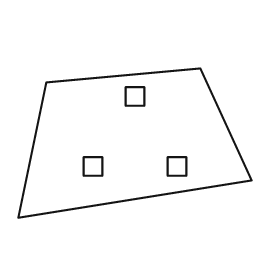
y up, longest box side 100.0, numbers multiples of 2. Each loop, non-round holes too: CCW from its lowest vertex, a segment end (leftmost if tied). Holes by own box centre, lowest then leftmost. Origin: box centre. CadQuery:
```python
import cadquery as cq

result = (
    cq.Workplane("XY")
    .moveTo(-50.0, -32.0)
    .lineTo(50.0, -16.0)
    .lineTo(28.0, 32.0)
    .lineTo(-38.0, 26.0)
    .close()
    .moveTo(-22.0, -14.0)
    .lineTo(-14.0, -14.0)
    .lineTo(-14.0, -6.0)
    .lineTo(-22.0, -6.0)
    .close()
    .moveTo(14.0, -14.0)
    .lineTo(22.0, -14.0)
    .lineTo(22.0, -6.0)
    .lineTo(14.0, -6.0)
    .close()
    .moveTo(-4.0, 16.0)
    .lineTo(4.0, 16.0)
    .lineTo(4.0, 24.0)
    .lineTo(-4.0, 24.0)
    .close()
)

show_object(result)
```